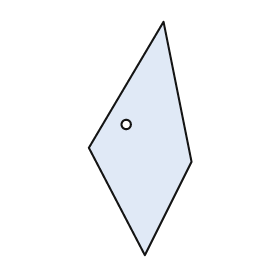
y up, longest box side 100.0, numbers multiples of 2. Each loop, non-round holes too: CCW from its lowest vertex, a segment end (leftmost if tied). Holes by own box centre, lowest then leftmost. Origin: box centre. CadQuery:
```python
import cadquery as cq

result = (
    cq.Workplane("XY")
    .moveTo(2.0, -50.0)
    .lineTo(22.0, -10.0)
    .lineTo(10.0, 50.0)
    .lineTo(-22.0, -4.0)
    .close()
    .moveTo(-6.0, 6.0)
    .circle(2.0)
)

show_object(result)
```